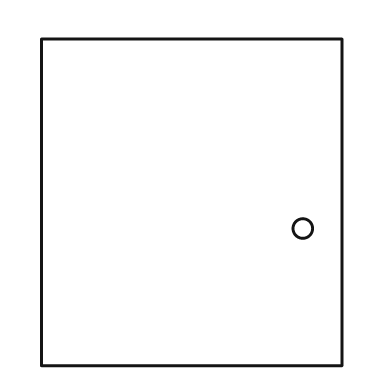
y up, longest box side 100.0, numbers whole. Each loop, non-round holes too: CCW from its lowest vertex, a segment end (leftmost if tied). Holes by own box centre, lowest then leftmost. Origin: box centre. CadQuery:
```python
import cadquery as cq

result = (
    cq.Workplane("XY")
    .moveTo(-46.0, -50.0)
    .lineTo(46.0, -50.0)
    .lineTo(46.0, 50.0)
    .lineTo(-46.0, 50.0)
    .close()
    .moveTo(34.0, -8.0)
    .circle(3.0)
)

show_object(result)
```